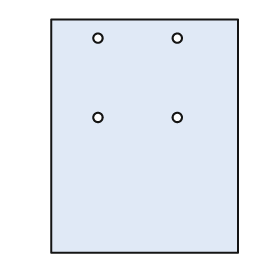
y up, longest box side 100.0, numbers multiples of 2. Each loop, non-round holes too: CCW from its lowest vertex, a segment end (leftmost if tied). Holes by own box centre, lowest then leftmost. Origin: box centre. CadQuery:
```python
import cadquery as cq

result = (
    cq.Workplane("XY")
    .moveTo(-40.0, -50.0)
    .lineTo(40.0, -50.0)
    .lineTo(40.0, 50.0)
    .lineTo(-40.0, 50.0)
    .close()
    .moveTo(-20.0, 8.0)
    .circle(2.0)
    .moveTo(14.0, 8.0)
    .circle(2.0)
    .moveTo(-20.0, 42.0)
    .circle(2.0)
    .moveTo(14.0, 42.0)
    .circle(2.0)
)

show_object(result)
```